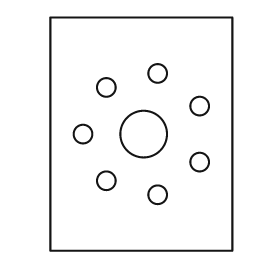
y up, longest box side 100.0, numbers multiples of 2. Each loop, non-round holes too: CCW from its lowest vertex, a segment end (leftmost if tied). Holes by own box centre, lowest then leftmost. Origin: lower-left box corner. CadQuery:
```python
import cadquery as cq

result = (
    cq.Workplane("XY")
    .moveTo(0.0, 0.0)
    .lineTo(78.0, 0.0)
    .lineTo(78.0, 100.0)
    .lineTo(0.0, 100.0)
    .close()
    .moveTo(46.0, 24.0)
    .circle(4.0)
    .moveTo(24.0, 30.0)
    .circle(4.0)
    .moveTo(64.0, 38.0)
    .circle(4.0)
    .moveTo(14.0, 50.0)
    .circle(4.0)
    .moveTo(40.0, 50.0)
    .circle(10.0)
    .moveTo(64.0, 62.0)
    .circle(4.0)
    .moveTo(24.0, 70.0)
    .circle(4.0)
    .moveTo(46.0, 76.0)
    .circle(4.0)
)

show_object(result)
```